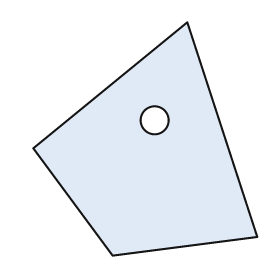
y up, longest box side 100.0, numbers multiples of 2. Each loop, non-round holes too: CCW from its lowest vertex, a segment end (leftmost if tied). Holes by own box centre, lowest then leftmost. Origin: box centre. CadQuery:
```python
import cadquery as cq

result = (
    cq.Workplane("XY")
    .moveTo(-14.0, -50.0)
    .lineTo(48.0, -42.0)
    .lineTo(18.0, 50.0)
    .lineTo(-48.0, -4.0)
    .close()
    .moveTo(4.0, 8.0)
    .circle(6.0)
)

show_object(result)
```